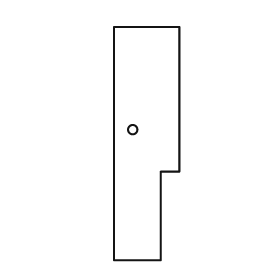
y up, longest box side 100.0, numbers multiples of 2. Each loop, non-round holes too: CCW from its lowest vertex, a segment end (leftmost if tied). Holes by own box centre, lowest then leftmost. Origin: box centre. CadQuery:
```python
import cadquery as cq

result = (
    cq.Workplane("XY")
    .moveTo(-14.0, -50.0)
    .lineTo(6.0, -50.0)
    .lineTo(6.0, -12.0)
    .lineTo(14.0, -12.0)
    .lineTo(14.0, 50.0)
    .lineTo(-14.0, 50.0)
    .close()
    .moveTo(-6.0, 6.0)
    .circle(2.0)
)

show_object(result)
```